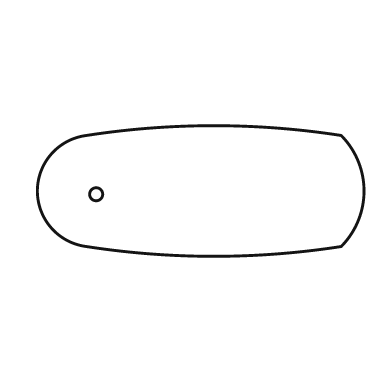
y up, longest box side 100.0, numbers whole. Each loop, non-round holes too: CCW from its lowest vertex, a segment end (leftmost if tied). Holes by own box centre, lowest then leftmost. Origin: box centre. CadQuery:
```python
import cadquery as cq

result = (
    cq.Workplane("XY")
    .moveTo(-35.0, -17.0)
    .threePointArc((4.0, -20.0), (43.0, -17.0))
    .threePointArc((50.0, 0.0), (43.0, 17.0))
    .threePointArc((4.0, 20.0), (-35.0, 17.0))
    .threePointArc((-50.0, 0.0), (-35.0, -17.0))
    .close()
    .moveTo(-32.0, -1.0)
    .circle(2.0)
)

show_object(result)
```